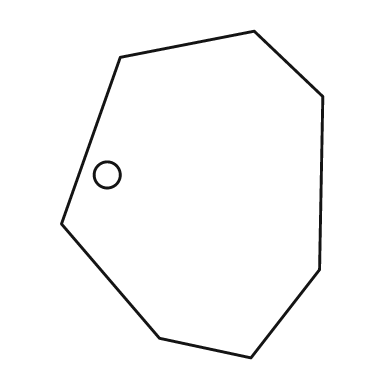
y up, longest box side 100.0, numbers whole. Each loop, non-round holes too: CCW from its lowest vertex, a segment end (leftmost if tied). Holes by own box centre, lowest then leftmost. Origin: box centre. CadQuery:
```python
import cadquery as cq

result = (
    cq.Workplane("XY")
    .moveTo(18.0, -50.0)
    .lineTo(39.0, -23.0)
    .lineTo(40.0, 30.0)
    .lineTo(19.0, 50.0)
    .lineTo(-22.0, 42.0)
    .lineTo(-40.0, -9.0)
    .lineTo(-10.0, -44.0)
    .close()
    .moveTo(-26.0, 6.0)
    .circle(4.0)
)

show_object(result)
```